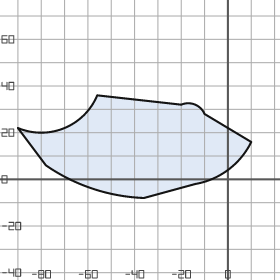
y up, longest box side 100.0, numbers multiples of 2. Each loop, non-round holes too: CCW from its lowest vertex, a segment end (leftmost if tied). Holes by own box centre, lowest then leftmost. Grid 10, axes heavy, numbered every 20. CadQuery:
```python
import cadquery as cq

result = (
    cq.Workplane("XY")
    .moveTo(-36.0, -8.0)
    .lineTo(-14.0, -2.0)
    .threePointArc((0.0, 4.0), (10.0, 16.0))
    .lineTo(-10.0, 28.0)
    .threePointArc((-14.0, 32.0), (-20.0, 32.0))
    .lineTo(-56.0, 36.0)
    .threePointArc((-70.0, 22.0), (-90.0, 22.0))
    .lineTo(-78.0, 6.0)
    .threePointArc((-58.0, -4.0), (-36.0, -8.0))
    .close()
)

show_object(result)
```